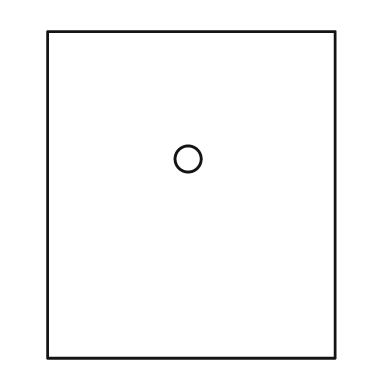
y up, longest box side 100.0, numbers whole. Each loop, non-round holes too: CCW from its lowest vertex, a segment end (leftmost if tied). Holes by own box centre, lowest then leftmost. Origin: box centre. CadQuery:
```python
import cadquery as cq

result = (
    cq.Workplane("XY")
    .moveTo(-44.0, -50.0)
    .lineTo(44.0, -50.0)
    .lineTo(44.0, 50.0)
    .lineTo(-44.0, 50.0)
    .close()
    .moveTo(-1.0, 11.0)
    .circle(4.0)
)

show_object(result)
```